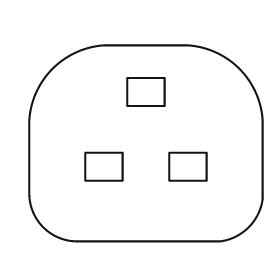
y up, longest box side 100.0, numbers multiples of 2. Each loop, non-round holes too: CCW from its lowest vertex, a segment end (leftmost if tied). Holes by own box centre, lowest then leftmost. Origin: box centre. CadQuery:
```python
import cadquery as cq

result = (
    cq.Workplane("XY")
    .moveTo(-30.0, -42.0)
    .lineTo(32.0, -42.0)
    .threePointArc((44.0, -36.0), (50.0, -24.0))
    .lineTo(50.0, 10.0)
    .threePointArc((40.0, 32.0), (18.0, 42.0))
    .lineTo(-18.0, 42.0)
    .threePointArc((-40.0, 32.0), (-50.0, 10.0))
    .lineTo(-50.0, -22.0)
    .threePointArc((-44.0, -36.0), (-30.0, -42.0))
    .close()
    .moveTo(-26.0, -16.0)
    .lineTo(-10.0, -16.0)
    .lineTo(-10.0, -4.0)
    .lineTo(-26.0, -4.0)
    .close()
    .moveTo(10.0, -16.0)
    .lineTo(26.0, -16.0)
    .lineTo(26.0, -4.0)
    .lineTo(10.0, -4.0)
    .close()
    .moveTo(-8.0, 16.0)
    .lineTo(8.0, 16.0)
    .lineTo(8.0, 28.0)
    .lineTo(-8.0, 28.0)
    .close()
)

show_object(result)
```